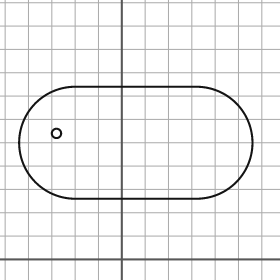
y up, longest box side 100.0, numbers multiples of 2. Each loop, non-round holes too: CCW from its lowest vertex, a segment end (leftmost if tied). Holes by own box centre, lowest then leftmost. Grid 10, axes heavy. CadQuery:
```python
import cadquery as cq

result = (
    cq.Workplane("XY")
    .moveTo(-20.0, 26.0)
    .lineTo(32.0, 26.0)
    .threePointArc((56.0, 50.0), (32.0, 74.0))
    .lineTo(-20.0, 74.0)
    .threePointArc((-44.0, 50.0), (-20.0, 26.0))
    .close()
    .moveTo(-28.0, 54.0)
    .circle(2.0)
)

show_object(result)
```